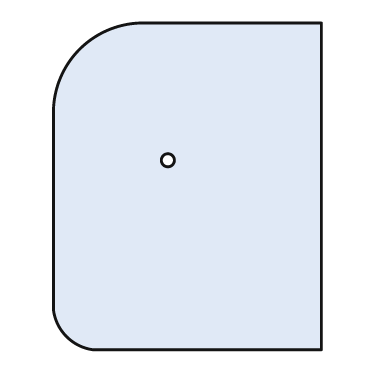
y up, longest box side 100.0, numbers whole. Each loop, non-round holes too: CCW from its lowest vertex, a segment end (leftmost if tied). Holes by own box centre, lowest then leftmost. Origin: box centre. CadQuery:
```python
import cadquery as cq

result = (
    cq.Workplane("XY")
    .moveTo(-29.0, -50.0)
    .lineTo(41.0, -50.0)
    .lineTo(41.0, 50.0)
    .lineTo(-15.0, 50.0)
    .threePointArc((-33.0, 42.0), (-41.0, 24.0))
    .lineTo(-41.0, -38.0)
    .threePointArc((-37.0, -46.0), (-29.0, -50.0))
    .close()
    .moveTo(-6.0, 8.0)
    .circle(2.0)
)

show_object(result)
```